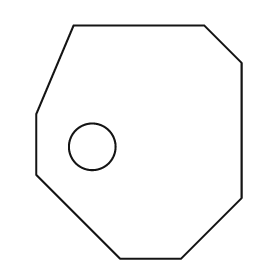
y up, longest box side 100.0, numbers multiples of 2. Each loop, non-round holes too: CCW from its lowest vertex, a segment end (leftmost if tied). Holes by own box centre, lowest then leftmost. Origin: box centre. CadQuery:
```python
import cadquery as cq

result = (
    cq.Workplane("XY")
    .moveTo(-8.0, -50.0)
    .lineTo(18.0, -50.0)
    .lineTo(44.0, -24.0)
    .lineTo(44.0, 34.0)
    .lineTo(28.0, 50.0)
    .lineTo(-28.0, 50.0)
    .lineTo(-44.0, 12.0)
    .lineTo(-44.0, -14.0)
    .close()
    .moveTo(-20.0, -2.0)
    .circle(10.0)
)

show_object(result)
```